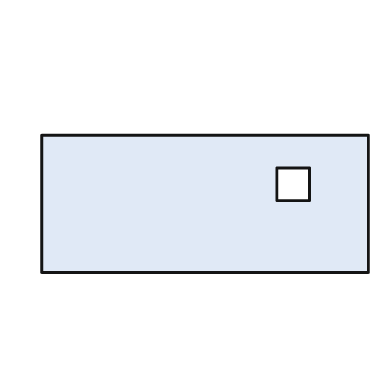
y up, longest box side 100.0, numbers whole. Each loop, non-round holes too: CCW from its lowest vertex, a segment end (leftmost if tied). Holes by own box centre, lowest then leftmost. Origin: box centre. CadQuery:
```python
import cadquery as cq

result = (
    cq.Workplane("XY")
    .moveTo(-50.0, -21.0)
    .lineTo(50.0, -21.0)
    .lineTo(50.0, 21.0)
    .lineTo(-50.0, 21.0)
    .close()
    .moveTo(22.0, 1.0)
    .lineTo(32.0, 1.0)
    .lineTo(32.0, 11.0)
    .lineTo(22.0, 11.0)
    .close()
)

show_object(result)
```